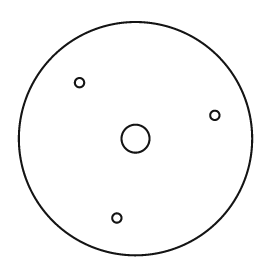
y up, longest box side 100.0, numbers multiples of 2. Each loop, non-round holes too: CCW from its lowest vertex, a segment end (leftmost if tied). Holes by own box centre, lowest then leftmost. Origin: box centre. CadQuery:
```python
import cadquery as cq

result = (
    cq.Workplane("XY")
    .moveTo(0.0, 0.0)
    .circle(50.0)
    .moveTo(-8.0, -34.0)
    .circle(2.0)
    .moveTo(0.0, 0.0)
    .circle(6.0)
    .moveTo(34.0, 10.0)
    .circle(2.0)
    .moveTo(-24.0, 24.0)
    .circle(2.0)
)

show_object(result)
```